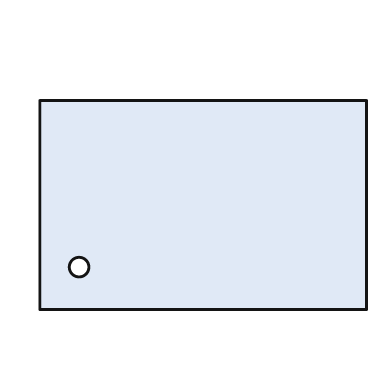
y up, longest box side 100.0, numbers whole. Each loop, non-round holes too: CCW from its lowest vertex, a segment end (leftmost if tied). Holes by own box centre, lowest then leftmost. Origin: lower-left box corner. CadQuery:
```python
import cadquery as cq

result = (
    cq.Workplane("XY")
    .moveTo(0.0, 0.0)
    .lineTo(100.0, 0.0)
    .lineTo(100.0, 64.0)
    .lineTo(0.0, 64.0)
    .close()
    .moveTo(12.0, 13.0)
    .circle(3.0)
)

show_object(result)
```